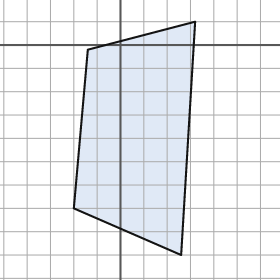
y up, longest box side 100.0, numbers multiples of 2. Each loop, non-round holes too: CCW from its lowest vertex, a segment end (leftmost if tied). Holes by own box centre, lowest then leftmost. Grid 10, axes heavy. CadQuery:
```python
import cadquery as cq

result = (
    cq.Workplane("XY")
    .moveTo(26.0, -90.0)
    .lineTo(32.0, 10.0)
    .lineTo(-14.0, -2.0)
    .lineTo(-20.0, -70.0)
    .close()
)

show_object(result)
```